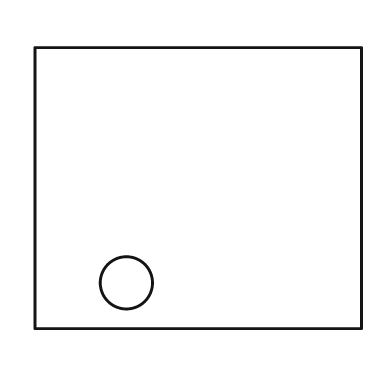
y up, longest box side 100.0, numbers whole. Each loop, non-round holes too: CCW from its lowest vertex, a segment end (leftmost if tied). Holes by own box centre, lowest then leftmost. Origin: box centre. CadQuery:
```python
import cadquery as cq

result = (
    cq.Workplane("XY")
    .moveTo(-50.0, -43.0)
    .lineTo(50.0, -43.0)
    .lineTo(50.0, 43.0)
    .lineTo(-50.0, 43.0)
    .close()
    .moveTo(-22.0, -29.0)
    .circle(8.0)
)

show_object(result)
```